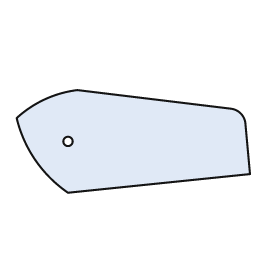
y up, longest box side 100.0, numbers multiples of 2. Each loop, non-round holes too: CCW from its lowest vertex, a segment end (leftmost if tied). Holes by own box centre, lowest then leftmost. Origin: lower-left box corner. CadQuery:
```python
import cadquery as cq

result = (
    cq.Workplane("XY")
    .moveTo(22.0, 0.0)
    .lineTo(100.0, 8.0)
    .lineTo(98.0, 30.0)
    .threePointArc((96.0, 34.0), (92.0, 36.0))
    .lineTo(26.0, 44.0)
    .threePointArc((12.0, 40.0), (0.0, 32.0))
    .threePointArc((8.0, 14.0), (22.0, 0.0))
    .close()
    .moveTo(22.0, 22.0)
    .circle(2.0)
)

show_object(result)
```